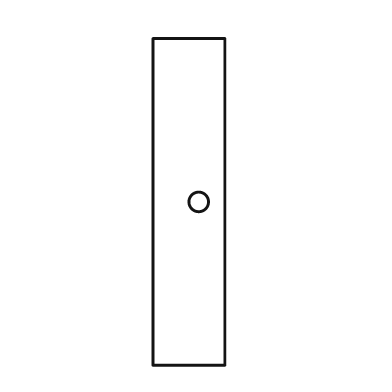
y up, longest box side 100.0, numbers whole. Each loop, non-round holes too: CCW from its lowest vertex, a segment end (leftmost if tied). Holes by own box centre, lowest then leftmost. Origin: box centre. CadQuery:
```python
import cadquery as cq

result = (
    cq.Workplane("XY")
    .moveTo(-11.0, -50.0)
    .lineTo(11.0, -50.0)
    .lineTo(11.0, 50.0)
    .lineTo(-11.0, 50.0)
    .close()
    .moveTo(3.0, 0.0)
    .circle(3.0)
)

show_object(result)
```